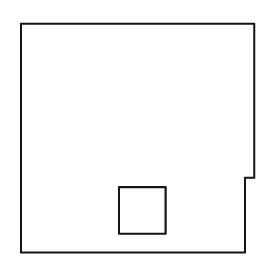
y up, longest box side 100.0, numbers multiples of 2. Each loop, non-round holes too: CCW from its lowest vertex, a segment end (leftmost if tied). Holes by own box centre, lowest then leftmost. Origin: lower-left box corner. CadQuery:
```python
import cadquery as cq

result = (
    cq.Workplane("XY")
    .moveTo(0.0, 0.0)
    .lineTo(96.0, 0.0)
    .lineTo(96.0, 32.0)
    .lineTo(100.0, 32.0)
    .lineTo(100.0, 98.0)
    .lineTo(0.0, 98.0)
    .close()
    .moveTo(42.0, 8.0)
    .lineTo(62.0, 8.0)
    .lineTo(62.0, 28.0)
    .lineTo(42.0, 28.0)
    .close()
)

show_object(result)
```